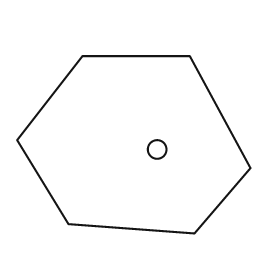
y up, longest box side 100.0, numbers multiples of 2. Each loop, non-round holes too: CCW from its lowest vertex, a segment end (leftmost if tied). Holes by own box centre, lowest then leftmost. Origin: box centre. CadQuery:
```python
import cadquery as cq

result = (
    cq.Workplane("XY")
    .moveTo(26.0, -38.0)
    .lineTo(50.0, -10.0)
    .lineTo(24.0, 38.0)
    .lineTo(-22.0, 38.0)
    .lineTo(-50.0, 2.0)
    .lineTo(-28.0, -34.0)
    .close()
    .moveTo(10.0, -2.0)
    .circle(4.0)
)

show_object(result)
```